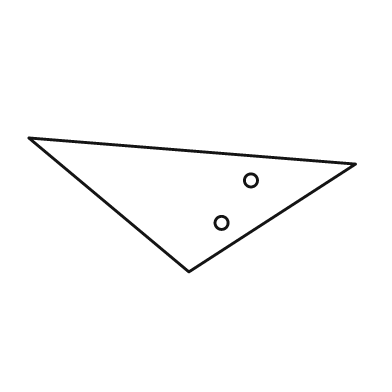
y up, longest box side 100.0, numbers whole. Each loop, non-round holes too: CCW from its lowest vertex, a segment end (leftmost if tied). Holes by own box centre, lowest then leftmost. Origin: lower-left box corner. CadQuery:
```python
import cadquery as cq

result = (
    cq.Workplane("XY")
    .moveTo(49.0, 0.0)
    .lineTo(100.0, 33.0)
    .lineTo(0.0, 41.0)
    .close()
    .moveTo(59.0, 15.0)
    .circle(2.0)
    .moveTo(68.0, 28.0)
    .circle(2.0)
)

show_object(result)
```